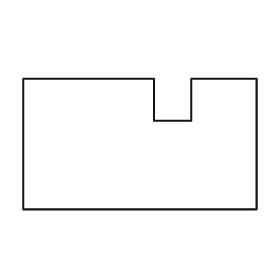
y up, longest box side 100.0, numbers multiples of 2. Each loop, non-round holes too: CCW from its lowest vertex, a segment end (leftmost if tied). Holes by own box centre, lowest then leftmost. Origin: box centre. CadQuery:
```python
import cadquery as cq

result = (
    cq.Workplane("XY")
    .moveTo(-50.0, -28.0)
    .lineTo(50.0, -28.0)
    .lineTo(50.0, 28.0)
    .lineTo(22.0, 28.0)
    .lineTo(22.0, 10.0)
    .lineTo(6.0, 10.0)
    .lineTo(6.0, 28.0)
    .lineTo(-50.0, 28.0)
    .close()
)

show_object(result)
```